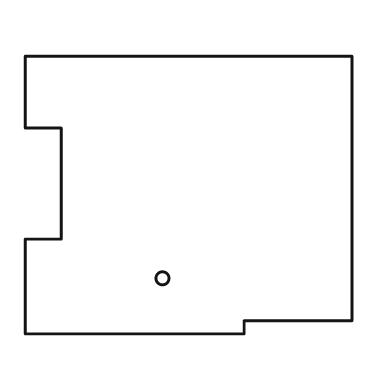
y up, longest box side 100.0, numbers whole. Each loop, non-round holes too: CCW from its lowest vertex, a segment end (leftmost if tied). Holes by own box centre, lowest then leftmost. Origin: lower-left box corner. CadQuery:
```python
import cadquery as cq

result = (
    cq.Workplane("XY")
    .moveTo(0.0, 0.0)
    .lineTo(67.0, 0.0)
    .lineTo(67.0, 4.0)
    .lineTo(100.0, 4.0)
    .lineTo(100.0, 85.0)
    .lineTo(0.0, 85.0)
    .lineTo(0.0, 63.0)
    .lineTo(11.0, 63.0)
    .lineTo(11.0, 29.0)
    .lineTo(0.0, 29.0)
    .close()
    .moveTo(42.0, 17.0)
    .circle(2.0)
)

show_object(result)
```